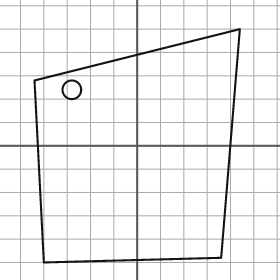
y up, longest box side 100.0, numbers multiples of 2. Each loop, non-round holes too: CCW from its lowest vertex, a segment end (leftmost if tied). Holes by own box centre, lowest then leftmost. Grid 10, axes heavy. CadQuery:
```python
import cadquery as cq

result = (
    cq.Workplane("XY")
    .moveTo(-40.0, -50.0)
    .lineTo(36.0, -48.0)
    .lineTo(44.0, 50.0)
    .lineTo(-44.0, 28.0)
    .close()
    .moveTo(-28.0, 24.0)
    .circle(4.0)
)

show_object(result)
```